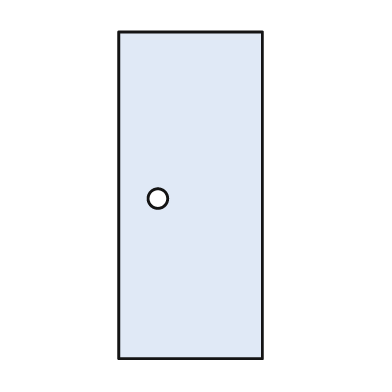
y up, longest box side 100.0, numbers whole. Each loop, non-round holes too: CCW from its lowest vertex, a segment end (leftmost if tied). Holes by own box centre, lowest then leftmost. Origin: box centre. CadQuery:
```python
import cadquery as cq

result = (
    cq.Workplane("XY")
    .moveTo(-22.0, -50.0)
    .lineTo(22.0, -50.0)
    .lineTo(22.0, 50.0)
    .lineTo(-22.0, 50.0)
    .close()
    .moveTo(-10.0, -1.0)
    .circle(3.0)
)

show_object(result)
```